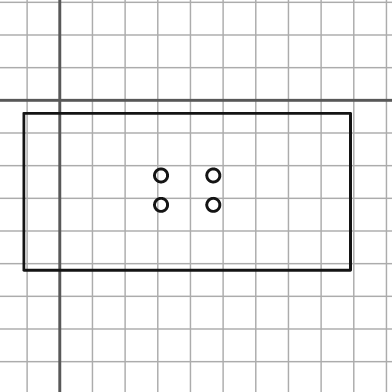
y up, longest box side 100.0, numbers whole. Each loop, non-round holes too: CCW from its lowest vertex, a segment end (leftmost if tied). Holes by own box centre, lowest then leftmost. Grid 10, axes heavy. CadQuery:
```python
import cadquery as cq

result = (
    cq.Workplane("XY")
    .moveTo(-11.0, -52.0)
    .lineTo(89.0, -52.0)
    .lineTo(89.0, -4.0)
    .lineTo(-11.0, -4.0)
    .close()
    .moveTo(31.0, -32.0)
    .circle(2.0)
    .moveTo(47.0, -32.0)
    .circle(2.0)
    .moveTo(31.0, -23.0)
    .circle(2.0)
    .moveTo(47.0, -23.0)
    .circle(2.0)
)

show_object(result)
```